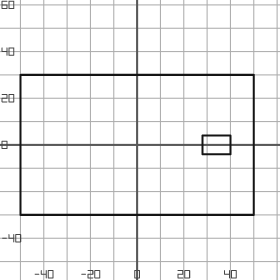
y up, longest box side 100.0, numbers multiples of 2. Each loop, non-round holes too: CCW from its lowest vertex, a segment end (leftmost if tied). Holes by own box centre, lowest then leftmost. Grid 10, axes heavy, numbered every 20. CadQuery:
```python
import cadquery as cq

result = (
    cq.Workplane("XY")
    .moveTo(-50.0, -30.0)
    .lineTo(50.0, -30.0)
    .lineTo(50.0, 30.0)
    .lineTo(-50.0, 30.0)
    .close()
    .moveTo(28.0, -4.0)
    .lineTo(40.0, -4.0)
    .lineTo(40.0, 4.0)
    .lineTo(28.0, 4.0)
    .close()
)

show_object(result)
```